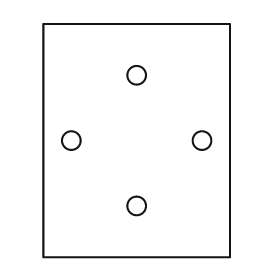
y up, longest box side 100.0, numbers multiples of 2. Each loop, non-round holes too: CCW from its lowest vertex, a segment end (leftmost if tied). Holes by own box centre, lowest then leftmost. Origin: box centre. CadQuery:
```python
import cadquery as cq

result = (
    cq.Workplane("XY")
    .moveTo(-40.0, -50.0)
    .lineTo(40.0, -50.0)
    .lineTo(40.0, 50.0)
    .lineTo(-40.0, 50.0)
    .close()
    .moveTo(0.0, -28.0)
    .circle(4.0)
    .moveTo(-28.0, 0.0)
    .circle(4.0)
    .moveTo(28.0, 0.0)
    .circle(4.0)
    .moveTo(0.0, 28.0)
    .circle(4.0)
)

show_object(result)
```